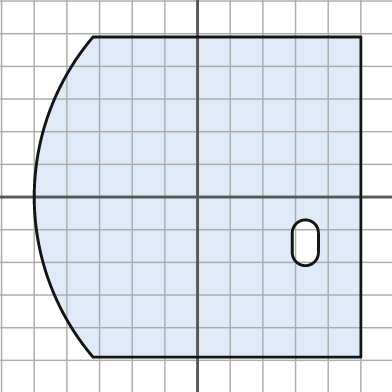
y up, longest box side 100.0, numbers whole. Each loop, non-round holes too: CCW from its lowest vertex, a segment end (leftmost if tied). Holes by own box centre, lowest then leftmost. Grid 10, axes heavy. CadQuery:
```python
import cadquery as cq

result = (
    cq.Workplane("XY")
    .moveTo(-32.0, -49.0)
    .lineTo(50.0, -49.0)
    .lineTo(50.0, 49.0)
    .lineTo(-32.0, 49.0)
    .threePointArc((-50.0, 0.0), (-32.0, -49.0))
    .close()
    .moveTo(29.0, -17.0)
    .threePointArc((33.0, -21.0), (37.0, -17.0))
    .lineTo(37.0, -11.0)
    .threePointArc((33.0, -7.0), (29.0, -11.0))
    .close()
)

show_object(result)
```